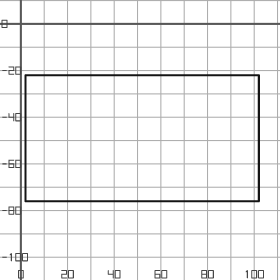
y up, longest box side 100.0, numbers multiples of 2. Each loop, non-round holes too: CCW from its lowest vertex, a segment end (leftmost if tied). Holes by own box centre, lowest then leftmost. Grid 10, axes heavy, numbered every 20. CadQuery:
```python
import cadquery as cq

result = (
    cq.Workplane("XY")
    .moveTo(2.0, -76.0)
    .lineTo(102.0, -76.0)
    .lineTo(102.0, -22.0)
    .lineTo(2.0, -22.0)
    .close()
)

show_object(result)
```